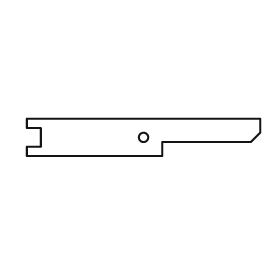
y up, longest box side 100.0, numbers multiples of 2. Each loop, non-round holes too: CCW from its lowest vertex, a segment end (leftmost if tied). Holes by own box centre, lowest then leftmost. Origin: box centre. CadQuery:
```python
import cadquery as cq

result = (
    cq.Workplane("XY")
    .moveTo(-50.0, -8.0)
    .lineTo(8.0, -8.0)
    .lineTo(8.0, -2.0)
    .lineTo(46.0, -2.0)
    .lineTo(50.0, 2.0)
    .lineTo(50.0, 8.0)
    .lineTo(-50.0, 8.0)
    .lineTo(-50.0, 4.0)
    .lineTo(-44.0, 4.0)
    .lineTo(-44.0, -4.0)
    .lineTo(-50.0, -4.0)
    .close()
    .moveTo(0.0, 0.0)
    .circle(2.0)
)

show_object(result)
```